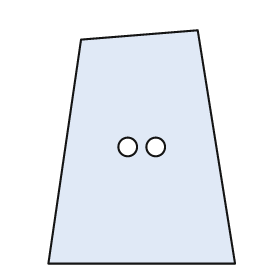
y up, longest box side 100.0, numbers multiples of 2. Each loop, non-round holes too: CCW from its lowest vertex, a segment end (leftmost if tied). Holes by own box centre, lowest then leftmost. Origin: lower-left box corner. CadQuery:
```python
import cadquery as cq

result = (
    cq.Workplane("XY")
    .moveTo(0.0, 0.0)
    .lineTo(80.0, 0.0)
    .lineTo(64.0, 100.0)
    .lineTo(14.0, 96.0)
    .close()
    .moveTo(34.0, 50.0)
    .circle(4.0)
    .moveTo(46.0, 50.0)
    .circle(4.0)
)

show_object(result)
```